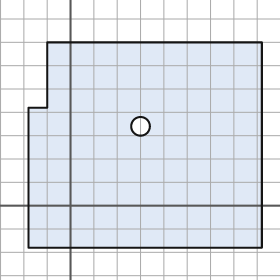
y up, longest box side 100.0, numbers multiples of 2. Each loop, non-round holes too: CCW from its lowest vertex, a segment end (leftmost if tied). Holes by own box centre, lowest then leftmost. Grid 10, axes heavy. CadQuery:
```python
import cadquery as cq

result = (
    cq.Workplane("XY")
    .moveTo(-18.0, -18.0)
    .lineTo(82.0, -18.0)
    .lineTo(82.0, 70.0)
    .lineTo(-10.0, 70.0)
    .lineTo(-10.0, 42.0)
    .lineTo(-18.0, 42.0)
    .close()
    .moveTo(30.0, 34.0)
    .circle(4.0)
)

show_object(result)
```